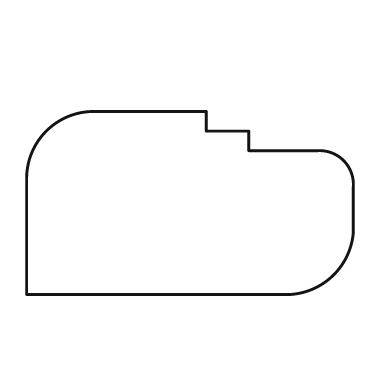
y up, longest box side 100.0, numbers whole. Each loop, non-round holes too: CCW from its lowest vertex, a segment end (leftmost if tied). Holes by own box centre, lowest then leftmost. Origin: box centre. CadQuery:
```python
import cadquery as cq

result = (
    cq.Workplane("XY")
    .moveTo(-50.0, -28.0)
    .lineTo(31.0, -28.0)
    .threePointArc((44.0, -22.0), (50.0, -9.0))
    .lineTo(50.0, 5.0)
    .threePointArc((47.0, 13.0), (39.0, 16.0))
    .lineTo(18.0, 16.0)
    .lineTo(18.0, 22.0)
    .lineTo(5.0, 22.0)
    .lineTo(5.0, 28.0)
    .lineTo(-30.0, 28.0)
    .threePointArc((-44.0, 22.0), (-50.0, 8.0))
    .close()
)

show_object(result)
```